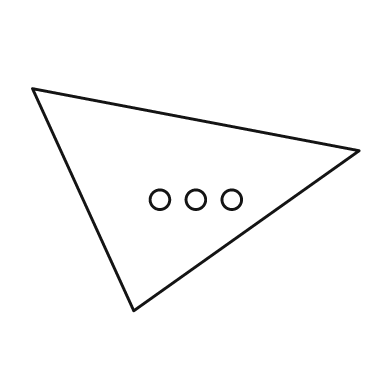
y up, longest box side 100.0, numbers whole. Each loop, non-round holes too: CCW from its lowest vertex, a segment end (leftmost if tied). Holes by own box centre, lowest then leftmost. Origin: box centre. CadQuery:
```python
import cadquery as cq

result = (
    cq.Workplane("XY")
    .moveTo(-19.0, -34.0)
    .lineTo(50.0, 15.0)
    .lineTo(-50.0, 34.0)
    .close()
    .moveTo(-11.0, 0.0)
    .circle(3.0)
    .moveTo(0.0, 0.0)
    .circle(3.0)
    .moveTo(11.0, 0.0)
    .circle(3.0)
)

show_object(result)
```